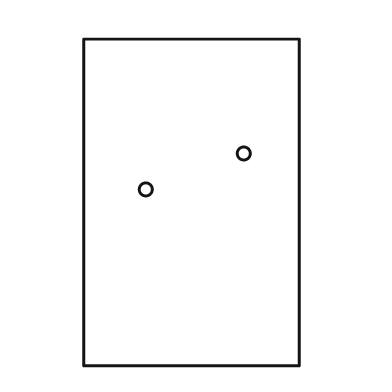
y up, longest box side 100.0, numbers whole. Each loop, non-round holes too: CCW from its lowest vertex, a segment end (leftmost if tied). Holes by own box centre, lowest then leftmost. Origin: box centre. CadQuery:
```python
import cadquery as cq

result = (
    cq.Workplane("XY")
    .moveTo(-33.0, -50.0)
    .lineTo(33.0, -50.0)
    .lineTo(33.0, 50.0)
    .lineTo(-33.0, 50.0)
    .close()
    .moveTo(-14.0, 4.0)
    .circle(2.0)
    .moveTo(16.0, 15.0)
    .circle(2.0)
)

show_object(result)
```